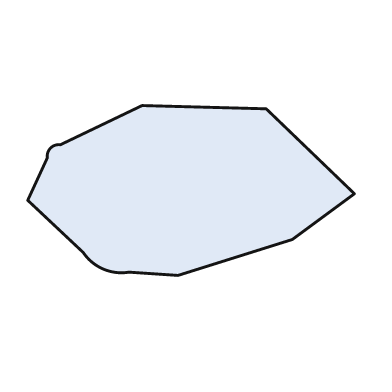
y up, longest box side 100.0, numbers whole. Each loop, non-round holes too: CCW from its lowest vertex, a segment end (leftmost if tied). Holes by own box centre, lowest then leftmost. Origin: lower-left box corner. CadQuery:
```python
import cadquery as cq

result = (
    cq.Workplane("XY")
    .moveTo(46.0, 0.0)
    .lineTo(81.0, 11.0)
    .lineTo(100.0, 25.0)
    .lineTo(73.0, 51.0)
    .lineTo(35.0, 52.0)
    .lineTo(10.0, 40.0)
    .threePointArc((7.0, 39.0), (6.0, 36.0))
    .lineTo(0.0, 23.0)
    .lineTo(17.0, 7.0)
    .threePointArc((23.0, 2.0), (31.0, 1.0))
    .close()
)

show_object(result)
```